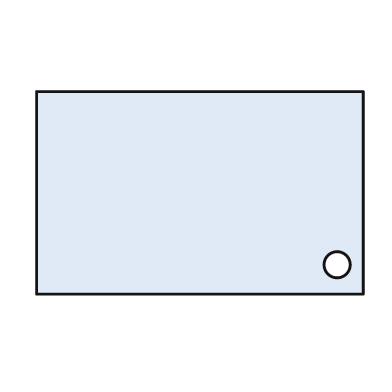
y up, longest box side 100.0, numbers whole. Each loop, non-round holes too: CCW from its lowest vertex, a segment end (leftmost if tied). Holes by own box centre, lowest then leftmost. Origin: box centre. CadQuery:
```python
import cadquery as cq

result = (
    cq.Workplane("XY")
    .moveTo(-50.0, -31.0)
    .lineTo(50.0, -31.0)
    .lineTo(50.0, 31.0)
    .lineTo(-50.0, 31.0)
    .close()
    .moveTo(42.0, -22.0)
    .circle(4.0)
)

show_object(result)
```